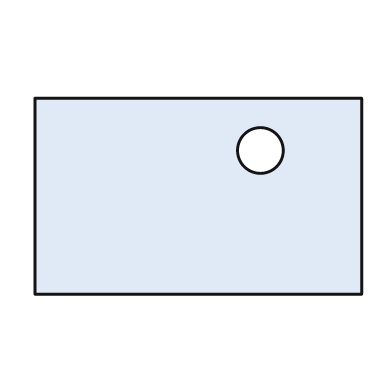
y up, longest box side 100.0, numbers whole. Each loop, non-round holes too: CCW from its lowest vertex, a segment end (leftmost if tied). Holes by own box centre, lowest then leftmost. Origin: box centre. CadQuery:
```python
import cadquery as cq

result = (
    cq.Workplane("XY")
    .moveTo(-50.0, -30.0)
    .lineTo(50.0, -30.0)
    .lineTo(50.0, 30.0)
    .lineTo(-50.0, 30.0)
    .close()
    .moveTo(19.0, 14.0)
    .circle(7.0)
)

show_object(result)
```